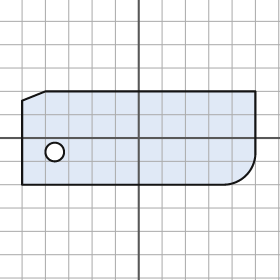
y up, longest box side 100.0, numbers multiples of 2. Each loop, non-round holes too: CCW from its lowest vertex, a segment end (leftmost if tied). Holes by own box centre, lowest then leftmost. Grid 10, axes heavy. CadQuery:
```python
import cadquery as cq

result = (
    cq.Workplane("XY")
    .moveTo(-50.0, -20.0)
    .lineTo(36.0, -20.0)
    .threePointArc((46.0, -16.0), (50.0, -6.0))
    .lineTo(50.0, 20.0)
    .lineTo(-40.0, 20.0)
    .lineTo(-50.0, 16.0)
    .close()
    .moveTo(-36.0, -6.0)
    .circle(4.0)
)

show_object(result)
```